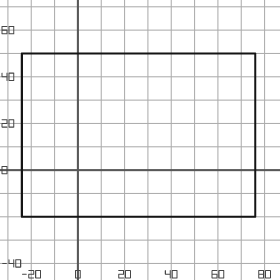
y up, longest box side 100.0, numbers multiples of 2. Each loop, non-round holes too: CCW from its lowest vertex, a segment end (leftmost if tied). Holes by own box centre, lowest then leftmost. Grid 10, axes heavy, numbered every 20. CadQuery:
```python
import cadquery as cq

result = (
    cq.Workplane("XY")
    .moveTo(-24.0, -20.0)
    .lineTo(76.0, -20.0)
    .lineTo(76.0, 50.0)
    .lineTo(-24.0, 50.0)
    .close()
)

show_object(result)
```